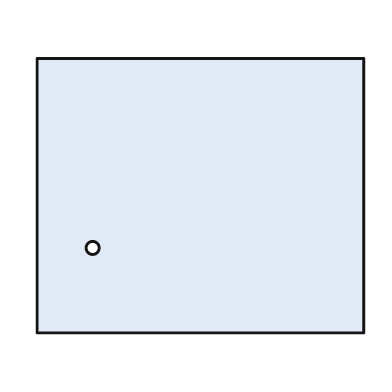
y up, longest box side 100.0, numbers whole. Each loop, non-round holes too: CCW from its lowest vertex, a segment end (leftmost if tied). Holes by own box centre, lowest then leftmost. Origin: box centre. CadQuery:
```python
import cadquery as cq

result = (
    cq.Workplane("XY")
    .moveTo(-50.0, -42.0)
    .lineTo(50.0, -42.0)
    .lineTo(50.0, 42.0)
    .lineTo(-50.0, 42.0)
    .close()
    .moveTo(-33.0, -16.0)
    .circle(2.0)
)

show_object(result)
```